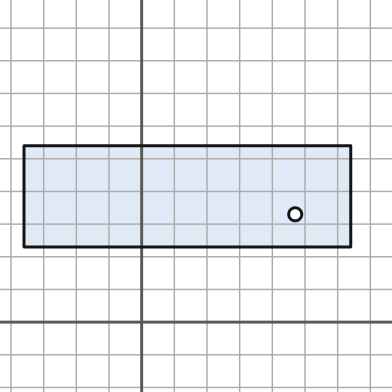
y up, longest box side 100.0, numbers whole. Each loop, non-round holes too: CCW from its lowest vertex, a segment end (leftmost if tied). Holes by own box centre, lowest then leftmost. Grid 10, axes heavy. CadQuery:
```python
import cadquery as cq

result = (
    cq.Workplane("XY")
    .moveTo(-36.0, 23.0)
    .lineTo(64.0, 23.0)
    .lineTo(64.0, 54.0)
    .lineTo(-36.0, 54.0)
    .close()
    .moveTo(47.0, 33.0)
    .circle(2.0)
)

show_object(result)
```